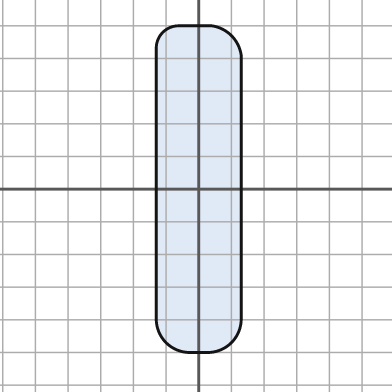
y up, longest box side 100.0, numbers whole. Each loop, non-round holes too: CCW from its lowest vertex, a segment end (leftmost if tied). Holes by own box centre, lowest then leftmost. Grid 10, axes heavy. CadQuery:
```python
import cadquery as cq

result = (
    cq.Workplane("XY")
    .moveTo(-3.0, -50.0)
    .lineTo(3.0, -50.0)
    .threePointArc((10.0, -47.0), (13.0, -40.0))
    .lineTo(13.0, 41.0)
    .threePointArc((10.0, 47.0), (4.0, 50.0))
    .lineTo(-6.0, 50.0)
    .threePointArc((-11.0, 48.0), (-13.0, 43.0))
    .lineTo(-13.0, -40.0)
    .threePointArc((-10.0, -47.0), (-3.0, -50.0))
    .close()
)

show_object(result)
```